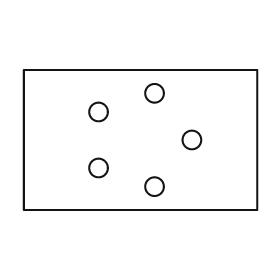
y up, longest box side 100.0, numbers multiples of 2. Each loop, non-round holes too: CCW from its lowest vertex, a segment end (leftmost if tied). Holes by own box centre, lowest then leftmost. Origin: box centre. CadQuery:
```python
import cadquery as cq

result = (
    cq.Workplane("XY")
    .moveTo(-50.0, -30.0)
    .lineTo(50.0, -30.0)
    .lineTo(50.0, 30.0)
    .lineTo(-50.0, 30.0)
    .close()
    .moveTo(6.0, -20.0)
    .circle(4.0)
    .moveTo(-18.0, -12.0)
    .circle(4.0)
    .moveTo(22.0, 0.0)
    .circle(4.0)
    .moveTo(-18.0, 12.0)
    .circle(4.0)
    .moveTo(6.0, 20.0)
    .circle(4.0)
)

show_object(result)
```